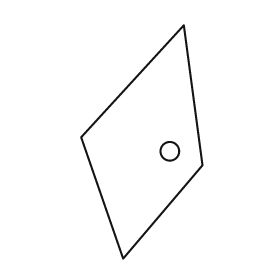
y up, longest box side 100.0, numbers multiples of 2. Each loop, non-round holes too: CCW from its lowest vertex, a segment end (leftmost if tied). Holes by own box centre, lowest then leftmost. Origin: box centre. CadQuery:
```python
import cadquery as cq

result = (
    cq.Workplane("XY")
    .moveTo(-8.0, -50.0)
    .lineTo(26.0, -10.0)
    .lineTo(18.0, 50.0)
    .lineTo(-26.0, 2.0)
    .close()
    .moveTo(12.0, -4.0)
    .circle(4.0)
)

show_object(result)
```